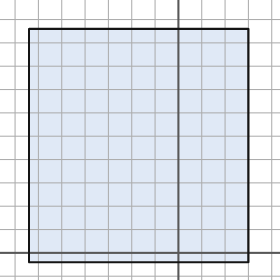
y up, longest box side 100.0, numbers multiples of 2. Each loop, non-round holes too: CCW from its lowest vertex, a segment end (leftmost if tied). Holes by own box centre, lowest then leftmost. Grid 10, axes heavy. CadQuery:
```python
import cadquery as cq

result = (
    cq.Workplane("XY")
    .moveTo(-64.0, -4.0)
    .lineTo(30.0, -4.0)
    .lineTo(30.0, 96.0)
    .lineTo(-64.0, 96.0)
    .close()
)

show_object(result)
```